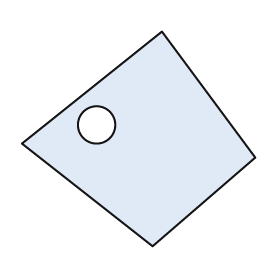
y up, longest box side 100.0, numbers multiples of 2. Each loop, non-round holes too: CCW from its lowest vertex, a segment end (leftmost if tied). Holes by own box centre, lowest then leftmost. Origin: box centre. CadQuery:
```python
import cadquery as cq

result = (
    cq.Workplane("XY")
    .moveTo(6.0, -46.0)
    .lineTo(50.0, -8.0)
    .lineTo(10.0, 46.0)
    .lineTo(-50.0, -2.0)
    .close()
    .moveTo(-18.0, 6.0)
    .circle(8.0)
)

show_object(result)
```